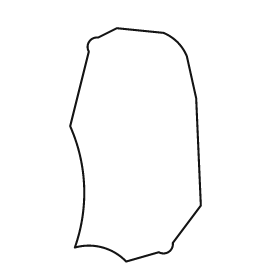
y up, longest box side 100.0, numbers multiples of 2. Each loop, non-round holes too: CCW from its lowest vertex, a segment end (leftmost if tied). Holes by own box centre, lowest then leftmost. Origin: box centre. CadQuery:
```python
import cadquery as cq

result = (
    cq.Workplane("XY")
    .moveTo(-4.0, -50.0)
    .lineTo(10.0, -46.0)
    .threePointArc((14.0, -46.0), (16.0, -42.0))
    .lineTo(28.0, -26.0)
    .lineTo(26.0, 20.0)
    .lineTo(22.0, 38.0)
    .threePointArc((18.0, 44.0), (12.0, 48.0))
    .lineTo(-8.0, 50.0)
    .lineTo(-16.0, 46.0)
    .threePointArc((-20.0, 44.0), (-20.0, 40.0))
    .lineTo(-28.0, 8.0)
    .threePointArc((-22.0, -18.0), (-26.0, -44.0))
    .threePointArc((-14.0, -44.0), (-4.0, -50.0))
    .close()
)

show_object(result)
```